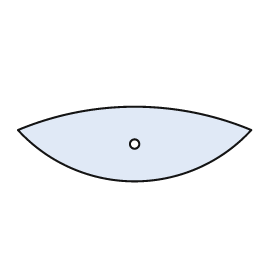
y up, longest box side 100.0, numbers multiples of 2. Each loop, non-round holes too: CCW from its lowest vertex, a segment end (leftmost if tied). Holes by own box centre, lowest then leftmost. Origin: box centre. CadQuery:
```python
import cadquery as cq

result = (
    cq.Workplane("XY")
    .moveTo(-50.0, 6.0)
    .threePointArc((0.0, -16.0), (50.0, 6.0))
    .threePointArc((0.0, 16.0), (-50.0, 6.0))
    .close()
    .moveTo(0.0, 0.0)
    .circle(2.0)
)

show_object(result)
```